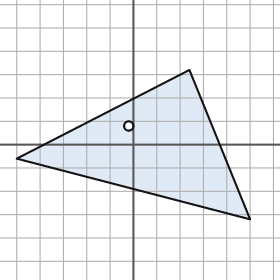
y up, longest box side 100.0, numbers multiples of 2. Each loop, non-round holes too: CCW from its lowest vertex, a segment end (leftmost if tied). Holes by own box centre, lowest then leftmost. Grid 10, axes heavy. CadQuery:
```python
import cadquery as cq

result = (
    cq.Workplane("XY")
    .moveTo(50.0, -32.0)
    .lineTo(24.0, 32.0)
    .lineTo(-50.0, -6.0)
    .close()
    .moveTo(-2.0, 8.0)
    .circle(2.0)
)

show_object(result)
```